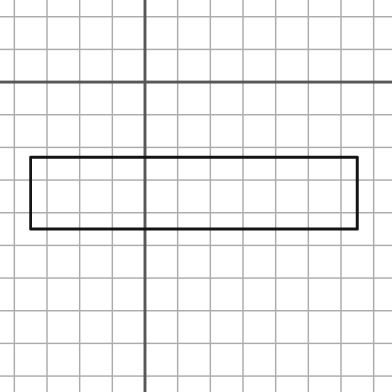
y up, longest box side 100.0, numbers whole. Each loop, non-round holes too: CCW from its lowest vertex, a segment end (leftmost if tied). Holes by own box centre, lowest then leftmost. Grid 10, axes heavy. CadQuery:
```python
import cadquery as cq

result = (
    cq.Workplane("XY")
    .moveTo(-35.0, -45.0)
    .lineTo(65.0, -45.0)
    .lineTo(65.0, -23.0)
    .lineTo(-35.0, -23.0)
    .close()
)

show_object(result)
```